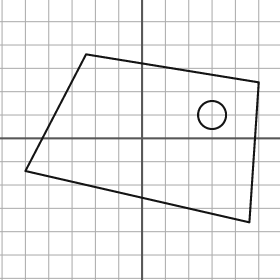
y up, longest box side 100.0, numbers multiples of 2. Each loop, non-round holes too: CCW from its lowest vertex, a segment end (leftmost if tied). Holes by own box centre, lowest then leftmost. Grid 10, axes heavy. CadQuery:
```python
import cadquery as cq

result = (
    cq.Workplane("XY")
    .moveTo(46.0, -36.0)
    .lineTo(50.0, 24.0)
    .lineTo(-24.0, 36.0)
    .lineTo(-50.0, -14.0)
    .close()
    .moveTo(30.0, 10.0)
    .circle(6.0)
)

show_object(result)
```